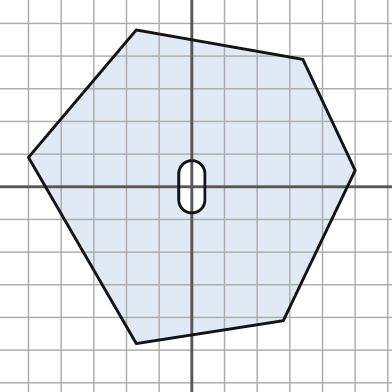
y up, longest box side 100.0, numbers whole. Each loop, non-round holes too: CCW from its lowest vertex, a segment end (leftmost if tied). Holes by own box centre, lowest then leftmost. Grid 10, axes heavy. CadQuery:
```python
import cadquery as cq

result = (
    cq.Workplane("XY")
    .moveTo(-17.0, -48.0)
    .lineTo(28.0, -41.0)
    .lineTo(50.0, 5.0)
    .lineTo(34.0, 39.0)
    .lineTo(-17.0, 48.0)
    .lineTo(-50.0, 9.0)
    .close()
    .moveTo(-4.0, -4.0)
    .threePointArc((0.0, -8.0), (4.0, -4.0))
    .lineTo(4.0, 4.0)
    .threePointArc((0.0, 8.0), (-4.0, 4.0))
    .close()
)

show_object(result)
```